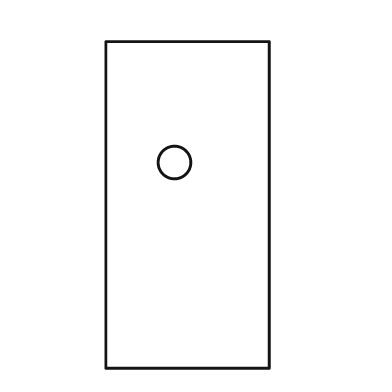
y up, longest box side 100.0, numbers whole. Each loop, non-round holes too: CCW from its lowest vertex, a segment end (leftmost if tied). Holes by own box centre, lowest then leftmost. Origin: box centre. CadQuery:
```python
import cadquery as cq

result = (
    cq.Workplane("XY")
    .moveTo(-25.0, -50.0)
    .lineTo(25.0, -50.0)
    .lineTo(25.0, 50.0)
    .lineTo(-25.0, 50.0)
    .close()
    .moveTo(-4.0, 13.0)
    .circle(5.0)
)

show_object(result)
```